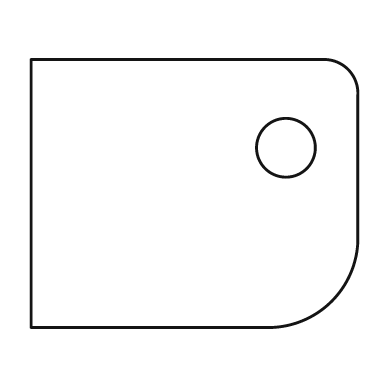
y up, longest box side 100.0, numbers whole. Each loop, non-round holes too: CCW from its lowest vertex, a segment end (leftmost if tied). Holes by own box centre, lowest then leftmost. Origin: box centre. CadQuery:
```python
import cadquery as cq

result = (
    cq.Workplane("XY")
    .moveTo(-50.0, -41.0)
    .lineTo(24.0, -41.0)
    .threePointArc((42.0, -33.0), (50.0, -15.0))
    .lineTo(50.0, 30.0)
    .threePointArc((47.0, 38.0), (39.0, 41.0))
    .lineTo(-50.0, 41.0)
    .close()
    .moveTo(28.0, 14.0)
    .circle(9.0)
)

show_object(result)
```